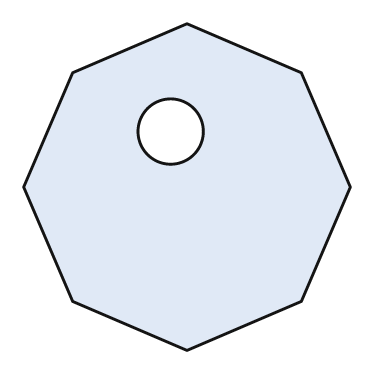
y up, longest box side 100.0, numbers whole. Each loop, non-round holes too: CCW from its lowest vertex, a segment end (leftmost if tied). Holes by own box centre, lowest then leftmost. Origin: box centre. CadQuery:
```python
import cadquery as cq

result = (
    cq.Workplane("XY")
    .moveTo(0.0, -50.0)
    .lineTo(35.0, -35.0)
    .lineTo(50.0, 0.0)
    .lineTo(35.0, 35.0)
    .lineTo(0.0, 50.0)
    .lineTo(-35.0, 35.0)
    .lineTo(-50.0, 0.0)
    .lineTo(-35.0, -35.0)
    .close()
    .moveTo(-5.0, 17.0)
    .circle(10.0)
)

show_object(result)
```